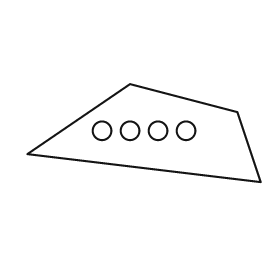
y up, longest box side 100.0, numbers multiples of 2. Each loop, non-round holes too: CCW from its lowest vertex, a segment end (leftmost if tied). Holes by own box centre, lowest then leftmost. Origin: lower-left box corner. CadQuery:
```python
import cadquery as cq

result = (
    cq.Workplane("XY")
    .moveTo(100.0, 0.0)
    .lineTo(90.0, 30.0)
    .lineTo(44.0, 42.0)
    .lineTo(0.0, 12.0)
    .close()
    .moveTo(32.0, 22.0)
    .circle(4.0)
    .moveTo(44.0, 22.0)
    .circle(4.0)
    .moveTo(56.0, 22.0)
    .circle(4.0)
    .moveTo(68.0, 22.0)
    .circle(4.0)
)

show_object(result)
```